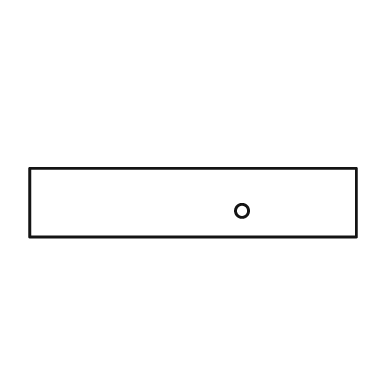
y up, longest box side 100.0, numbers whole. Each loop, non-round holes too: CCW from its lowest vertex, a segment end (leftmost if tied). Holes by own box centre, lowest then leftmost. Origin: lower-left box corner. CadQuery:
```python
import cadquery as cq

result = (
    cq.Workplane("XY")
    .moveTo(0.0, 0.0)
    .lineTo(100.0, 0.0)
    .lineTo(100.0, 21.0)
    .lineTo(0.0, 21.0)
    .close()
    .moveTo(65.0, 8.0)
    .circle(2.0)
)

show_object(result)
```